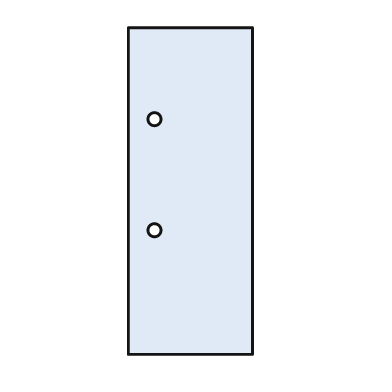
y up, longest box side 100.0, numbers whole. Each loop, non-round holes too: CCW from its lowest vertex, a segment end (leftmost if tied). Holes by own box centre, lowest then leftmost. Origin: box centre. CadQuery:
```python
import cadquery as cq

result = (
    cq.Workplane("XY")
    .moveTo(-19.0, -50.0)
    .lineTo(19.0, -50.0)
    .lineTo(19.0, 50.0)
    .lineTo(-19.0, 50.0)
    .close()
    .moveTo(-11.0, -12.0)
    .circle(2.0)
    .moveTo(-11.0, 22.0)
    .circle(2.0)
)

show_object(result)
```